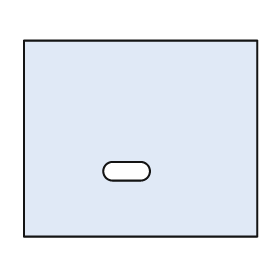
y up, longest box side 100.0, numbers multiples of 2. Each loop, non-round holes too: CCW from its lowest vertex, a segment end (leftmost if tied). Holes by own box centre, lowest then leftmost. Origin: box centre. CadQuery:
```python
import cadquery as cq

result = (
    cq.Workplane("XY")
    .moveTo(-50.0, -42.0)
    .lineTo(50.0, -42.0)
    .lineTo(50.0, 42.0)
    .lineTo(-50.0, 42.0)
    .close()
    .moveTo(-12.0, -18.0)
    .lineTo(0.0, -18.0)
    .threePointArc((4.0, -14.0), (0.0, -10.0))
    .lineTo(-12.0, -10.0)
    .threePointArc((-16.0, -14.0), (-12.0, -18.0))
    .close()
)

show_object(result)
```